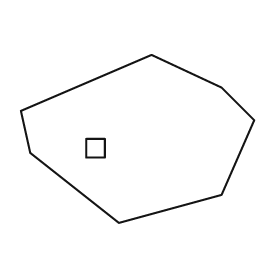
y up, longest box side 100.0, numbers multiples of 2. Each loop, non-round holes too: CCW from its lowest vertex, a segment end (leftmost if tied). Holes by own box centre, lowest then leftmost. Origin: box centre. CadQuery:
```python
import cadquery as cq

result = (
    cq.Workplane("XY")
    .moveTo(-8.0, -36.0)
    .lineTo(36.0, -24.0)
    .lineTo(50.0, 8.0)
    .lineTo(36.0, 22.0)
    .lineTo(6.0, 36.0)
    .lineTo(-50.0, 12.0)
    .lineTo(-46.0, -6.0)
    .close()
    .moveTo(-22.0, -8.0)
    .lineTo(-14.0, -8.0)
    .lineTo(-14.0, 0.0)
    .lineTo(-22.0, 0.0)
    .close()
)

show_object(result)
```